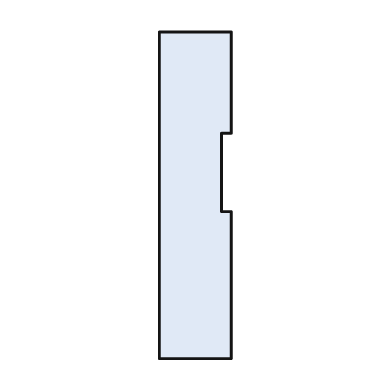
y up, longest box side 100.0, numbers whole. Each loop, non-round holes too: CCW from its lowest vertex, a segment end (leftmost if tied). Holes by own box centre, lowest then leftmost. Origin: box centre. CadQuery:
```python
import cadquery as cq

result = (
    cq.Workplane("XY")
    .moveTo(-11.0, -50.0)
    .lineTo(11.0, -50.0)
    .lineTo(11.0, -5.0)
    .lineTo(8.0, -5.0)
    .lineTo(8.0, 19.0)
    .lineTo(11.0, 19.0)
    .lineTo(11.0, 50.0)
    .lineTo(-11.0, 50.0)
    .close()
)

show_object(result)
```